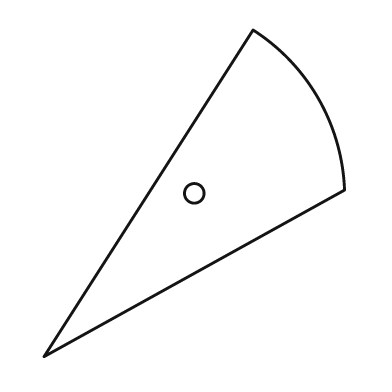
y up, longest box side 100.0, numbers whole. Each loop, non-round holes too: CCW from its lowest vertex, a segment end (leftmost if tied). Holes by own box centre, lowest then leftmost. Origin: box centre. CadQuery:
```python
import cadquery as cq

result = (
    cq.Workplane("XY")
    .moveTo(-46.0, -50.0)
    .lineTo(46.0, 1.0)
    .threePointArc((38.0, 29.0), (18.0, 50.0))
    .close()
    .moveTo(0.0, 0.0)
    .circle(3.0)
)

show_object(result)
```